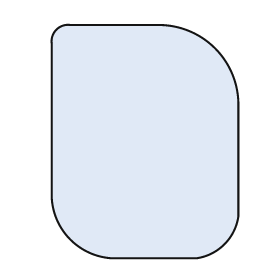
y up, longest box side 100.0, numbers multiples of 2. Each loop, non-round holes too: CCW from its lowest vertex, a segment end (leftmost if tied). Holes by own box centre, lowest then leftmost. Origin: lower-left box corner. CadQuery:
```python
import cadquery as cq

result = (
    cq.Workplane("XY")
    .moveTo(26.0, 0.0)
    .lineTo(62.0, 0.0)
    .threePointArc((74.0, 6.0), (80.0, 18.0))
    .lineTo(80.0, 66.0)
    .threePointArc((70.0, 90.0), (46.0, 100.0))
    .lineTo(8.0, 100.0)
    .threePointArc((2.0, 98.0), (0.0, 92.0))
    .lineTo(0.0, 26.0)
    .threePointArc((8.0, 8.0), (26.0, 0.0))
    .close()
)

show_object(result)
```